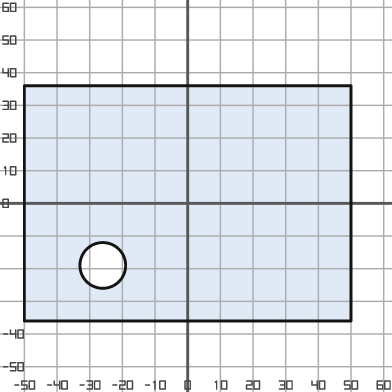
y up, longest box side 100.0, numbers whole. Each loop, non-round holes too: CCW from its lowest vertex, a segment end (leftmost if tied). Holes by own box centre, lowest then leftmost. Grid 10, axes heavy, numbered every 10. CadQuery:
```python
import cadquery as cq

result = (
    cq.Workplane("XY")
    .moveTo(-50.0, -36.0)
    .lineTo(50.0, -36.0)
    .lineTo(50.0, 36.0)
    .lineTo(-50.0, 36.0)
    .close()
    .moveTo(-26.0, -19.0)
    .circle(7.0)
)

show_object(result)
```